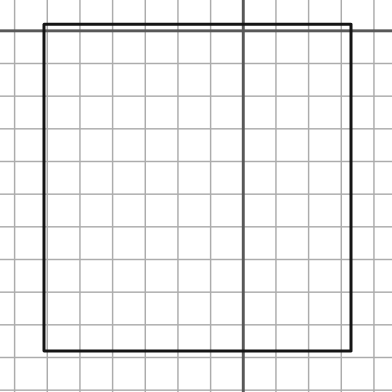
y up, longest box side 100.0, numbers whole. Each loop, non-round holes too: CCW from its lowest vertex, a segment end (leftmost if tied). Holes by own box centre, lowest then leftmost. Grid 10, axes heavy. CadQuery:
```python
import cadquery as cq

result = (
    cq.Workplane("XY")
    .moveTo(-61.0, -98.0)
    .lineTo(33.0, -98.0)
    .lineTo(33.0, 2.0)
    .lineTo(-61.0, 2.0)
    .close()
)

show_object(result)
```